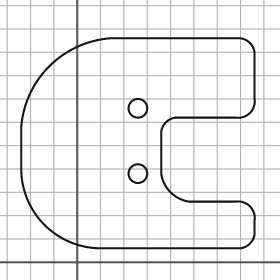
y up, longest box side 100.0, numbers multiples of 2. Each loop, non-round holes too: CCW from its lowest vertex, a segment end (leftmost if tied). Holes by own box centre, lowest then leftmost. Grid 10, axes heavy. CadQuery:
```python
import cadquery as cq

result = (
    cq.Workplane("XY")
    .moveTo(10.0, 6.0)
    .lineTo(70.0, 6.0)
    .threePointArc((74.0, 8.0), (76.0, 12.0))
    .lineTo(76.0, 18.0)
    .threePointArc((74.0, 24.0), (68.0, 26.0))
    .lineTo(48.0, 26.0)
    .threePointArc((40.0, 30.0), (36.0, 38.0))
    .lineTo(36.0, 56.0)
    .threePointArc((38.0, 60.0), (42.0, 62.0))
    .lineTo(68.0, 62.0)
    .threePointArc((74.0, 64.0), (76.0, 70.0))
    .lineTo(76.0, 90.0)
    .threePointArc((74.0, 94.0), (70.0, 96.0))
    .lineTo(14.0, 96.0)
    .threePointArc((-12.0, 84.0), (-24.0, 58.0))
    .lineTo(-24.0, 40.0)
    .threePointArc((-14.0, 16.0), (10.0, 6.0))
    .close()
    .moveTo(26.0, 38.0)
    .circle(4.0)
    .moveTo(26.0, 66.0)
    .circle(4.0)
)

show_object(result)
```